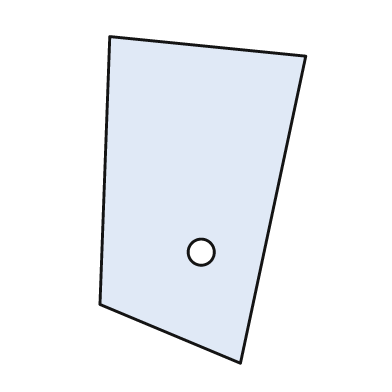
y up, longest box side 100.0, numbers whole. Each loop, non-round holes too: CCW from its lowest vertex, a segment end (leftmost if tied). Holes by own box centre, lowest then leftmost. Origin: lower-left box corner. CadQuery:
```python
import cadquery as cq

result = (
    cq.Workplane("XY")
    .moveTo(43.0, 0.0)
    .lineTo(63.0, 94.0)
    .lineTo(3.0, 100.0)
    .lineTo(0.0, 18.0)
    .close()
    .moveTo(31.0, 34.0)
    .circle(4.0)
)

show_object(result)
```